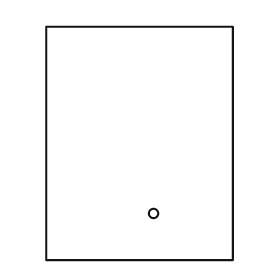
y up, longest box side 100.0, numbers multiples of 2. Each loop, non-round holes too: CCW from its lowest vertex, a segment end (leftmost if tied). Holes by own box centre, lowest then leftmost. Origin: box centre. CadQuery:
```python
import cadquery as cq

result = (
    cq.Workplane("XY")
    .moveTo(-40.0, -50.0)
    .lineTo(40.0, -50.0)
    .lineTo(40.0, 50.0)
    .lineTo(-40.0, 50.0)
    .close()
    .moveTo(6.0, -30.0)
    .circle(2.0)
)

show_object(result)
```